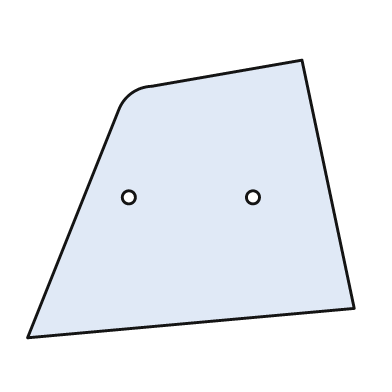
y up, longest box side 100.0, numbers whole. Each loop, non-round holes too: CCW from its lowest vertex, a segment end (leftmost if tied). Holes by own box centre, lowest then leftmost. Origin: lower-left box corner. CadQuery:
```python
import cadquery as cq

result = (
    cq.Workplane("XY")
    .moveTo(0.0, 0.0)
    .lineTo(100.0, 9.0)
    .lineTo(84.0, 85.0)
    .lineTo(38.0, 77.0)
    .threePointArc((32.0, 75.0), (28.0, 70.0))
    .close()
    .moveTo(31.0, 43.0)
    .circle(2.0)
    .moveTo(69.0, 43.0)
    .circle(2.0)
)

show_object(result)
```